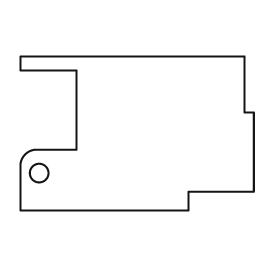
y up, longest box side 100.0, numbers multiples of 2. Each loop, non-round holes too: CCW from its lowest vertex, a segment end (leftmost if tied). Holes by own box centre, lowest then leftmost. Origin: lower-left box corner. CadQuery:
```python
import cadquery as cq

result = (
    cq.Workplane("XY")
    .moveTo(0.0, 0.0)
    .lineTo(72.0, 0.0)
    .lineTo(72.0, 8.0)
    .lineTo(100.0, 8.0)
    .lineTo(100.0, 42.0)
    .lineTo(96.0, 42.0)
    .lineTo(96.0, 66.0)
    .lineTo(0.0, 66.0)
    .lineTo(0.0, 60.0)
    .lineTo(24.0, 60.0)
    .lineTo(24.0, 26.0)
    .lineTo(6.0, 26.0)
    .threePointArc((2.0, 24.0), (0.0, 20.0))
    .close()
    .moveTo(8.0, 16.0)
    .circle(4.0)
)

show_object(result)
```